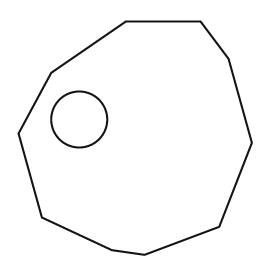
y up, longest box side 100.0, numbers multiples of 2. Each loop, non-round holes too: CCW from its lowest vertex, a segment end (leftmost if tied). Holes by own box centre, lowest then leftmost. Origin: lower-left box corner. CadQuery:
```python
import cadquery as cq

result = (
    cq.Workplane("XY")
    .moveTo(54.0, 0.0)
    .lineTo(86.0, 12.0)
    .lineTo(100.0, 48.0)
    .lineTo(90.0, 84.0)
    .lineTo(78.0, 100.0)
    .lineTo(46.0, 100.0)
    .lineTo(14.0, 78.0)
    .lineTo(0.0, 52.0)
    .lineTo(10.0, 16.0)
    .lineTo(40.0, 2.0)
    .close()
    .moveTo(26.0, 58.0)
    .circle(12.0)
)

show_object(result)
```